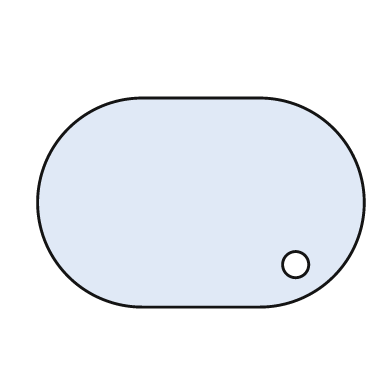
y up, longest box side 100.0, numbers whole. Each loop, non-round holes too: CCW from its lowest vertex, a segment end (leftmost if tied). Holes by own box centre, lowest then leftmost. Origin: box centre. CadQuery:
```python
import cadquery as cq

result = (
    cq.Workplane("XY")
    .moveTo(-18.0, -32.0)
    .lineTo(18.0, -32.0)
    .threePointArc((50.0, 0.0), (18.0, 32.0))
    .lineTo(-18.0, 32.0)
    .threePointArc((-50.0, 0.0), (-18.0, -32.0))
    .close()
    .moveTo(29.0, -19.0)
    .circle(4.0)
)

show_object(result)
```